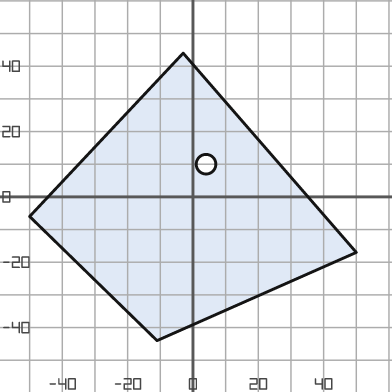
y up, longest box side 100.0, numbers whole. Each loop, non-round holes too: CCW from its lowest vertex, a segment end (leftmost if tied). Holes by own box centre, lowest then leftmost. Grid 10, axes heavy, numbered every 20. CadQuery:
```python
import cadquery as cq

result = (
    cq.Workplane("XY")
    .moveTo(-11.0, -44.0)
    .lineTo(50.0, -17.0)
    .lineTo(-3.0, 44.0)
    .lineTo(-50.0, -6.0)
    .close()
    .moveTo(4.0, 10.0)
    .circle(3.0)
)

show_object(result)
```